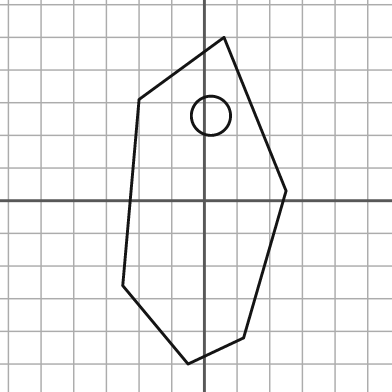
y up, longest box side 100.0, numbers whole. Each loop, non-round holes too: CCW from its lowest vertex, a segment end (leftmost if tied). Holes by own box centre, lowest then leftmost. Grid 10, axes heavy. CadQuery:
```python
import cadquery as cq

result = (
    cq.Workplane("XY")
    .moveTo(-5.0, -50.0)
    .lineTo(12.0, -42.0)
    .lineTo(25.0, 3.0)
    .lineTo(6.0, 50.0)
    .lineTo(-20.0, 31.0)
    .lineTo(-25.0, -26.0)
    .close()
    .moveTo(2.0, 26.0)
    .circle(6.0)
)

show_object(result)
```